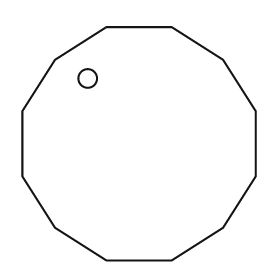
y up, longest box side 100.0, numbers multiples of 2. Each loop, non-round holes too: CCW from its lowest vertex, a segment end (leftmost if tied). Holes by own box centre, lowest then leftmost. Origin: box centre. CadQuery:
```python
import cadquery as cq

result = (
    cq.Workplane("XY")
    .moveTo(-14.0, -50.0)
    .lineTo(14.0, -50.0)
    .lineTo(36.0, -36.0)
    .lineTo(50.0, -14.0)
    .lineTo(50.0, 14.0)
    .lineTo(36.0, 36.0)
    .lineTo(14.0, 50.0)
    .lineTo(-14.0, 50.0)
    .lineTo(-36.0, 36.0)
    .lineTo(-50.0, 14.0)
    .lineTo(-50.0, -14.0)
    .lineTo(-36.0, -36.0)
    .close()
    .moveTo(-22.0, 28.0)
    .circle(4.0)
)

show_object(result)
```